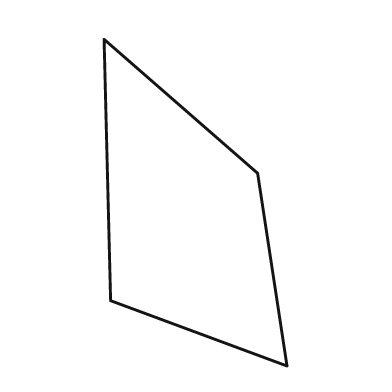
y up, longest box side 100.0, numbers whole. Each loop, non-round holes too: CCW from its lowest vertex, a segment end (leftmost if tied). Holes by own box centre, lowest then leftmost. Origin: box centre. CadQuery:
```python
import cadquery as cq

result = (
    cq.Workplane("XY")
    .moveTo(28.0, -50.0)
    .lineTo(19.0, 9.0)
    .lineTo(-28.0, 50.0)
    .lineTo(-26.0, -30.0)
    .close()
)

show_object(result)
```